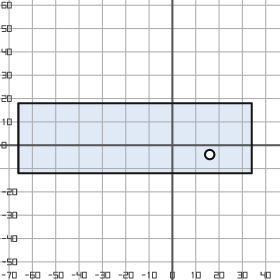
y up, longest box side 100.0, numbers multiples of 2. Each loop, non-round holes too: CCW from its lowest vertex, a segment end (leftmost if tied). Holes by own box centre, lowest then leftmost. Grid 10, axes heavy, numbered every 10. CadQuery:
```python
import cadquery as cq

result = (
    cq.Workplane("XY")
    .moveTo(-66.0, -12.0)
    .lineTo(34.0, -12.0)
    .lineTo(34.0, 18.0)
    .lineTo(-66.0, 18.0)
    .close()
    .moveTo(16.0, -4.0)
    .circle(2.0)
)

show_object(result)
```